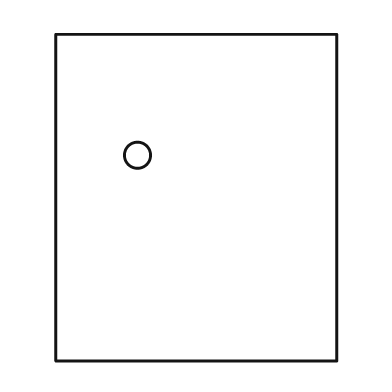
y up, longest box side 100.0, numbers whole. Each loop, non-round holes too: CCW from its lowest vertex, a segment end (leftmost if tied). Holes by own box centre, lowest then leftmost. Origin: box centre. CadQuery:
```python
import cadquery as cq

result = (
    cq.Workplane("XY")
    .moveTo(-43.0, -50.0)
    .lineTo(43.0, -50.0)
    .lineTo(43.0, 50.0)
    .lineTo(-43.0, 50.0)
    .close()
    .moveTo(-18.0, 13.0)
    .circle(4.0)
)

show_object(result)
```